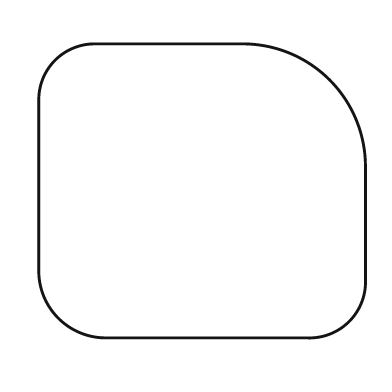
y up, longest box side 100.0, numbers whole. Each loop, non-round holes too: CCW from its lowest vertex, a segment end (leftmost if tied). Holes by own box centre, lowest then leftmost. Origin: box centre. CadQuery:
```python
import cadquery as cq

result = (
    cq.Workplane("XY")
    .moveTo(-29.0, -45.0)
    .lineTo(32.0, -45.0)
    .threePointArc((45.0, -40.0), (50.0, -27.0))
    .lineTo(50.0, 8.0)
    .threePointArc((39.0, 34.0), (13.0, 45.0))
    .lineTo(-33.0, 45.0)
    .threePointArc((-45.0, 40.0), (-50.0, 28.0))
    .lineTo(-50.0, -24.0)
    .threePointArc((-44.0, -39.0), (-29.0, -45.0))
    .close()
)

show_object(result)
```